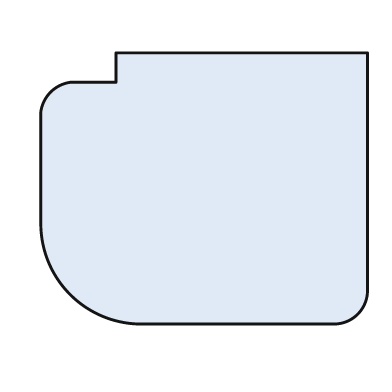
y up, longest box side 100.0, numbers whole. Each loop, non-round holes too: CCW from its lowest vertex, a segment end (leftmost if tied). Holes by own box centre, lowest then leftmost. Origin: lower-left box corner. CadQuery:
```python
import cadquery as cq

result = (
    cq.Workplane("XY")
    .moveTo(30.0, 0.0)
    .lineTo(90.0, 0.0)
    .threePointArc((97.0, 3.0), (100.0, 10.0))
    .lineTo(100.0, 83.0)
    .lineTo(23.0, 83.0)
    .lineTo(23.0, 74.0)
    .lineTo(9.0, 74.0)
    .threePointArc((3.0, 71.0), (0.0, 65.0))
    .lineTo(0.0, 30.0)
    .threePointArc((9.0, 9.0), (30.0, 0.0))
    .close()
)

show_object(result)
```